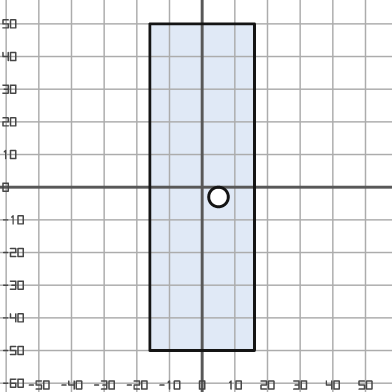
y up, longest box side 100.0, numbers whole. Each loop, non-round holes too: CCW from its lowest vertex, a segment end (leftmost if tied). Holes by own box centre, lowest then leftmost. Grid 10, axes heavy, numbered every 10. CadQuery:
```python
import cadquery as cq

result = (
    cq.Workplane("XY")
    .moveTo(-16.0, -50.0)
    .lineTo(16.0, -50.0)
    .lineTo(16.0, 50.0)
    .lineTo(-16.0, 50.0)
    .close()
    .moveTo(5.0, -3.0)
    .circle(3.0)
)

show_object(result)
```